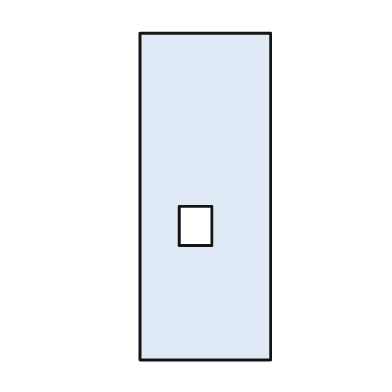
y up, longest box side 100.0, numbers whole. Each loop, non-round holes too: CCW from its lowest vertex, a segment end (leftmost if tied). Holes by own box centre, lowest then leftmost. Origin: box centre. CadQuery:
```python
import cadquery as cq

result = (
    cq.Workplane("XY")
    .moveTo(-20.0, -50.0)
    .lineTo(20.0, -50.0)
    .lineTo(20.0, 50.0)
    .lineTo(-20.0, 50.0)
    .close()
    .moveTo(-8.0, -15.0)
    .lineTo(2.0, -15.0)
    .lineTo(2.0, -3.0)
    .lineTo(-8.0, -3.0)
    .close()
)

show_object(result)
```